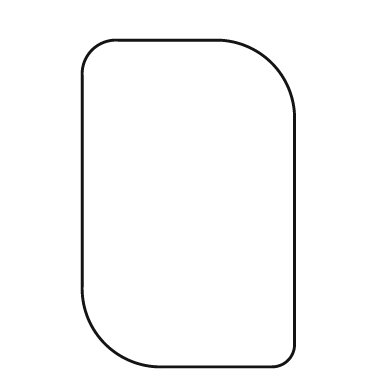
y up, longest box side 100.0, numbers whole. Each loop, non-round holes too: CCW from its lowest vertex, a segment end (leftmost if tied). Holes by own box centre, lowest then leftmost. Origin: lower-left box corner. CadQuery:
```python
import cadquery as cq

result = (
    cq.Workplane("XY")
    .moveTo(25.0, 0.0)
    .lineTo(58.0, 0.0)
    .threePointArc((63.0, 2.0), (65.0, 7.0))
    .lineTo(65.0, 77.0)
    .threePointArc((58.0, 93.0), (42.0, 100.0))
    .lineTo(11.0, 100.0)
    .threePointArc((3.0, 97.0), (0.0, 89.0))
    .lineTo(0.0, 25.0)
    .threePointArc((7.0, 7.0), (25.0, 0.0))
    .close()
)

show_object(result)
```